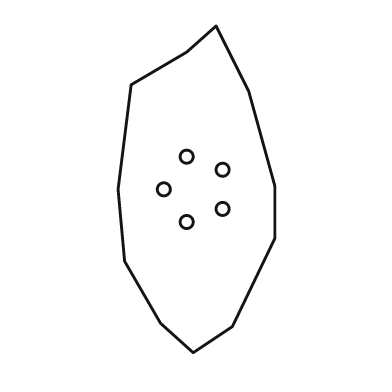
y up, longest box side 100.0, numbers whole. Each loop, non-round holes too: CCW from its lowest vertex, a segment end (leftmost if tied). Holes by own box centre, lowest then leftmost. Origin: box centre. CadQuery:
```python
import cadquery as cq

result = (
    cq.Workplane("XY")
    .moveTo(-1.0, -50.0)
    .lineTo(11.0, -42.0)
    .lineTo(24.0, -15.0)
    .lineTo(24.0, 1.0)
    .lineTo(16.0, 30.0)
    .lineTo(6.0, 50.0)
    .lineTo(-3.0, 42.0)
    .lineTo(-20.0, 32.0)
    .lineTo(-24.0, 0.0)
    .lineTo(-22.0, -22.0)
    .lineTo(-11.0, -41.0)
    .close()
    .moveTo(-3.0, -10.0)
    .circle(2.0)
    .moveTo(8.0, -6.0)
    .circle(2.0)
    .moveTo(-10.0, 0.0)
    .circle(2.0)
    .moveTo(8.0, 6.0)
    .circle(2.0)
    .moveTo(-3.0, 10.0)
    .circle(2.0)
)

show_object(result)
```